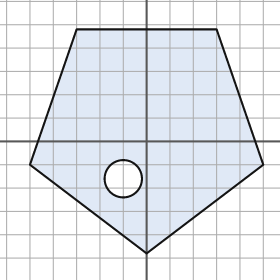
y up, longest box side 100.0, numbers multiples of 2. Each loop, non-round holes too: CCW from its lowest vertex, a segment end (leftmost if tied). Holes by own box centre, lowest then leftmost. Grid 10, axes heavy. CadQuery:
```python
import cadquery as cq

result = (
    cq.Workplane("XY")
    .moveTo(0.0, -48.0)
    .lineTo(50.0, -10.0)
    .lineTo(30.0, 48.0)
    .lineTo(-30.0, 48.0)
    .lineTo(-50.0, -10.0)
    .close()
    .moveTo(-10.0, -16.0)
    .circle(8.0)
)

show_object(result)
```